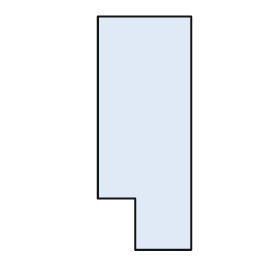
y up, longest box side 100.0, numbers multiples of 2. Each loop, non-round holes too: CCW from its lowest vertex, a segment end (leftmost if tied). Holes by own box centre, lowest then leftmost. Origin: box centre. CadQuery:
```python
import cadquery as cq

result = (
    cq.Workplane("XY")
    .moveTo(-4.0, -50.0)
    .lineTo(20.0, -50.0)
    .lineTo(20.0, 50.0)
    .lineTo(-20.0, 50.0)
    .lineTo(-20.0, -28.0)
    .lineTo(-4.0, -28.0)
    .close()
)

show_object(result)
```